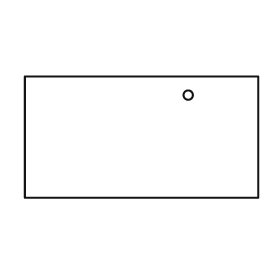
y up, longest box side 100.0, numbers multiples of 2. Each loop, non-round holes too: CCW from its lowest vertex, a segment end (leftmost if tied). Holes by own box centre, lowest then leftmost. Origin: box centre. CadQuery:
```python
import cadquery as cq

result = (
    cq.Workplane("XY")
    .moveTo(-50.0, -26.0)
    .lineTo(50.0, -26.0)
    .lineTo(50.0, 26.0)
    .lineTo(-50.0, 26.0)
    .close()
    .moveTo(20.0, 18.0)
    .circle(2.0)
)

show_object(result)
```